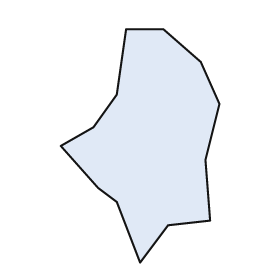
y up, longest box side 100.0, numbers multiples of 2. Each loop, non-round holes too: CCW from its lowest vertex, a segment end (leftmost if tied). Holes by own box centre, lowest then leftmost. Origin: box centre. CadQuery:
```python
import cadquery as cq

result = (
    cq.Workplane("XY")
    .moveTo(0.0, -50.0)
    .lineTo(12.0, -34.0)
    .lineTo(30.0, -32.0)
    .lineTo(28.0, -6.0)
    .lineTo(34.0, 18.0)
    .lineTo(26.0, 36.0)
    .lineTo(10.0, 50.0)
    .lineTo(-6.0, 50.0)
    .lineTo(-10.0, 22.0)
    .lineTo(-20.0, 8.0)
    .lineTo(-34.0, 0.0)
    .lineTo(-18.0, -18.0)
    .lineTo(-10.0, -24.0)
    .close()
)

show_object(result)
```